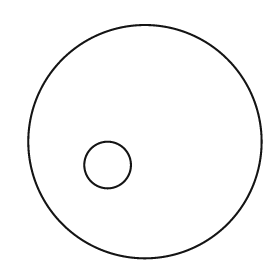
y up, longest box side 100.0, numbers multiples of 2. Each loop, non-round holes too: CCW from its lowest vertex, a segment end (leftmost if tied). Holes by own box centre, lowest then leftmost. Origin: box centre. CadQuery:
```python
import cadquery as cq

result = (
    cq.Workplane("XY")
    .moveTo(0.0, 0.0)
    .circle(50.0)
    .moveTo(-16.0, -10.0)
    .circle(10.0)
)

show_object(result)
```